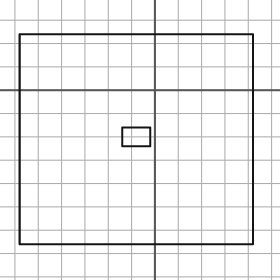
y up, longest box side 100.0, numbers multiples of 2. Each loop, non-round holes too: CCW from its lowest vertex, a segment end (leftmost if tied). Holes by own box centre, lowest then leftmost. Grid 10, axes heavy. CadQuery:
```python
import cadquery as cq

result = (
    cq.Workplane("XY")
    .moveTo(-58.0, -66.0)
    .lineTo(42.0, -66.0)
    .lineTo(42.0, 24.0)
    .lineTo(-58.0, 24.0)
    .close()
    .moveTo(-14.0, -24.0)
    .lineTo(-2.0, -24.0)
    .lineTo(-2.0, -16.0)
    .lineTo(-14.0, -16.0)
    .close()
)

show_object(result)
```